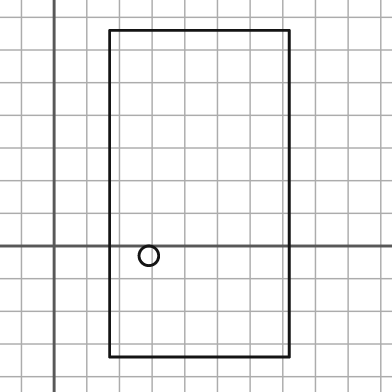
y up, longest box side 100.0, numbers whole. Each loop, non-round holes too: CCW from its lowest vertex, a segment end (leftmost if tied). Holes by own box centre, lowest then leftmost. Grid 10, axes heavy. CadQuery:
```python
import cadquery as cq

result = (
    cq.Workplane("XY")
    .moveTo(17.0, -34.0)
    .lineTo(72.0, -34.0)
    .lineTo(72.0, 66.0)
    .lineTo(17.0, 66.0)
    .close()
    .moveTo(29.0, -3.0)
    .circle(3.0)
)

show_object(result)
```